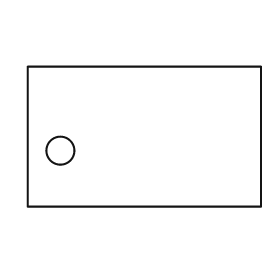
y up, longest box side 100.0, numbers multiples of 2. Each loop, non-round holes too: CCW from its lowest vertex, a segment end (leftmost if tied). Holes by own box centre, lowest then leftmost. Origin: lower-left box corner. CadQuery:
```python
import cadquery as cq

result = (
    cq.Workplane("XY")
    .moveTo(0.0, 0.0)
    .lineTo(100.0, 0.0)
    .lineTo(100.0, 60.0)
    .lineTo(0.0, 60.0)
    .close()
    .moveTo(14.0, 24.0)
    .circle(6.0)
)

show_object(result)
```